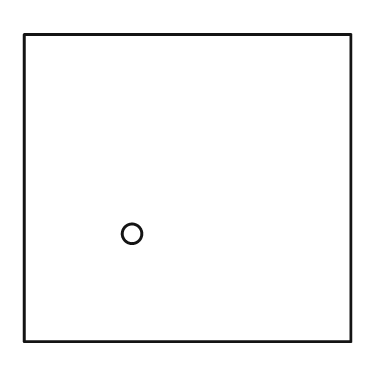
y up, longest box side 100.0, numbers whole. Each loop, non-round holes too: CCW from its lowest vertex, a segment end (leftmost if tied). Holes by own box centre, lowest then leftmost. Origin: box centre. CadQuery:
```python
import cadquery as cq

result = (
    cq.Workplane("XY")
    .moveTo(-50.0, -47.0)
    .lineTo(50.0, -47.0)
    .lineTo(50.0, 47.0)
    .lineTo(-50.0, 47.0)
    .close()
    .moveTo(-17.0, -14.0)
    .circle(3.0)
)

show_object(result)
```